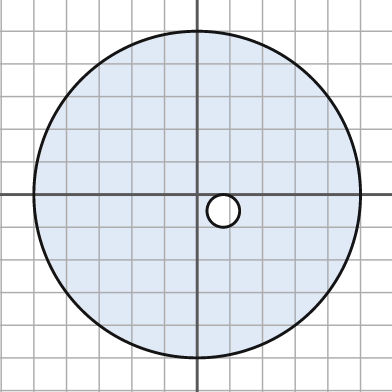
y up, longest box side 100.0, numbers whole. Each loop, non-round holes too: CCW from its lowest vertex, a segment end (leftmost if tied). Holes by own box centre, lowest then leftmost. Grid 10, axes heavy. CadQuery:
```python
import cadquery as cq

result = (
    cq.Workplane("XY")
    .moveTo(0.0, 0.0)
    .circle(50.0)
    .moveTo(8.0, -5.0)
    .circle(5.0)
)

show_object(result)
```